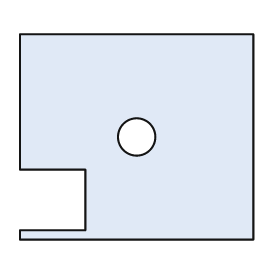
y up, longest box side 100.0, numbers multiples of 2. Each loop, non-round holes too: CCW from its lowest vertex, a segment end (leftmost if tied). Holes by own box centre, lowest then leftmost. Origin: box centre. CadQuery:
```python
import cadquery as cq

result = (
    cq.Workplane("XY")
    .moveTo(-50.0, -44.0)
    .lineTo(50.0, -44.0)
    .lineTo(50.0, 44.0)
    .lineTo(-50.0, 44.0)
    .lineTo(-50.0, -14.0)
    .lineTo(-22.0, -14.0)
    .lineTo(-22.0, -40.0)
    .lineTo(-50.0, -40.0)
    .close()
    .moveTo(0.0, 0.0)
    .circle(8.0)
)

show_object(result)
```